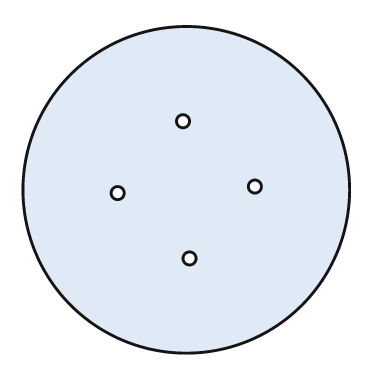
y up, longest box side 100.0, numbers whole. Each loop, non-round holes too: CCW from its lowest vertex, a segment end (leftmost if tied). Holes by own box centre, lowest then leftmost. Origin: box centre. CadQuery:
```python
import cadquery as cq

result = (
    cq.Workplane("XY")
    .moveTo(0.0, 0.0)
    .circle(50.0)
    .moveTo(1.0, -21.0)
    .circle(2.0)
    .moveTo(-21.0, -1.0)
    .circle(2.0)
    .moveTo(21.0, 1.0)
    .circle(2.0)
    .moveTo(-1.0, 21.0)
    .circle(2.0)
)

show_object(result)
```